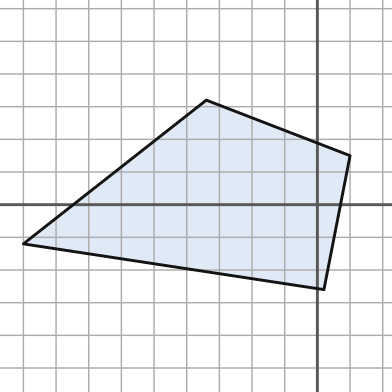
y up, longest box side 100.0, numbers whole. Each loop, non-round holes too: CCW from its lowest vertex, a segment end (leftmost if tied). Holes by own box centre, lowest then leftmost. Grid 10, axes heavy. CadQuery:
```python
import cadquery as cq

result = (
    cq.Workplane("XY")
    .moveTo(2.0, -26.0)
    .lineTo(10.0, 15.0)
    .lineTo(-34.0, 32.0)
    .lineTo(-90.0, -12.0)
    .close()
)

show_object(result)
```